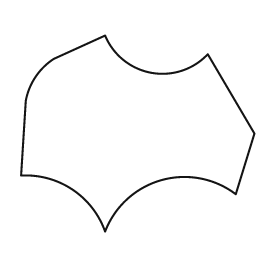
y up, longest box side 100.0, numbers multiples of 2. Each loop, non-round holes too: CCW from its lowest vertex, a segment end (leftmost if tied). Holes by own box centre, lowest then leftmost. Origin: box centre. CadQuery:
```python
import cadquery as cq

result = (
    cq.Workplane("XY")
    .moveTo(-14.0, -42.0)
    .threePointArc((10.0, -20.0), (42.0, -26.0))
    .lineTo(50.0, 0.0)
    .lineTo(30.0, 34.0)
    .threePointArc((6.0, 26.0), (-14.0, 42.0))
    .lineTo(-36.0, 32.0)
    .threePointArc((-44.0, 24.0), (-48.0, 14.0))
    .lineTo(-50.0, -18.0)
    .threePointArc((-28.0, -24.0), (-14.0, -42.0))
    .close()
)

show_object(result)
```